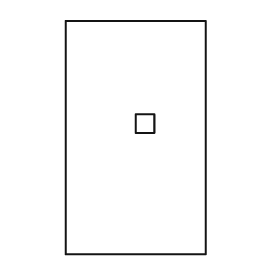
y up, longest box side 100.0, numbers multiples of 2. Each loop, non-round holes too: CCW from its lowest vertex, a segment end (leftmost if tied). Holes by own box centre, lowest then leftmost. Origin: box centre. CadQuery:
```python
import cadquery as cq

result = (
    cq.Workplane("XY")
    .moveTo(-30.0, -50.0)
    .lineTo(30.0, -50.0)
    .lineTo(30.0, 50.0)
    .lineTo(-30.0, 50.0)
    .close()
    .moveTo(0.0, 2.0)
    .lineTo(8.0, 2.0)
    .lineTo(8.0, 10.0)
    .lineTo(0.0, 10.0)
    .close()
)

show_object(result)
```